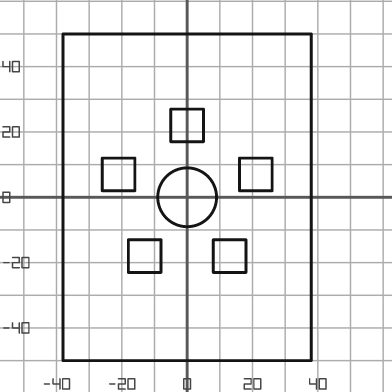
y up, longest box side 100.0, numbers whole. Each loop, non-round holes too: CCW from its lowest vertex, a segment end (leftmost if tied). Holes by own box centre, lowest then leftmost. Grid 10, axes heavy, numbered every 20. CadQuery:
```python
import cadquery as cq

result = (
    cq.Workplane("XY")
    .moveTo(-38.0, -50.0)
    .lineTo(38.0, -50.0)
    .lineTo(38.0, 50.0)
    .lineTo(-38.0, 50.0)
    .close()
    .moveTo(-18.0, -23.0)
    .lineTo(-8.0, -23.0)
    .lineTo(-8.0, -13.0)
    .lineTo(-18.0, -13.0)
    .close()
    .moveTo(8.0, -23.0)
    .lineTo(18.0, -23.0)
    .lineTo(18.0, -13.0)
    .lineTo(8.0, -13.0)
    .close()
    .moveTo(0.0, 0.0)
    .circle(9.0)
    .moveTo(-26.0, 2.0)
    .lineTo(-16.0, 2.0)
    .lineTo(-16.0, 12.0)
    .lineTo(-26.0, 12.0)
    .close()
    .moveTo(16.0, 2.0)
    .lineTo(26.0, 2.0)
    .lineTo(26.0, 12.0)
    .lineTo(16.0, 12.0)
    .close()
    .moveTo(-5.0, 17.0)
    .lineTo(5.0, 17.0)
    .lineTo(5.0, 27.0)
    .lineTo(-5.0, 27.0)
    .close()
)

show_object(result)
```